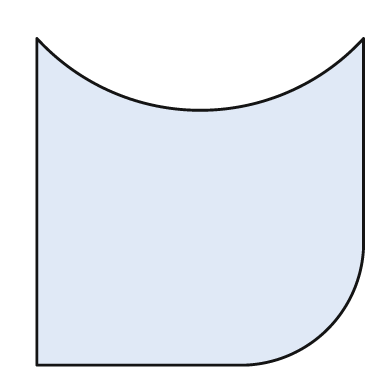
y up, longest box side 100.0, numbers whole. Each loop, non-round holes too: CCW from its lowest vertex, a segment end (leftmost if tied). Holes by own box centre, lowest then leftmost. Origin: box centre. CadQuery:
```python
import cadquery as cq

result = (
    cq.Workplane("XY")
    .moveTo(-50.0, -50.0)
    .lineTo(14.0, -50.0)
    .threePointArc((39.0, -39.0), (50.0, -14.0))
    .lineTo(50.0, 50.0)
    .threePointArc((0.0, 28.0), (-50.0, 50.0))
    .close()
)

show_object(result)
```